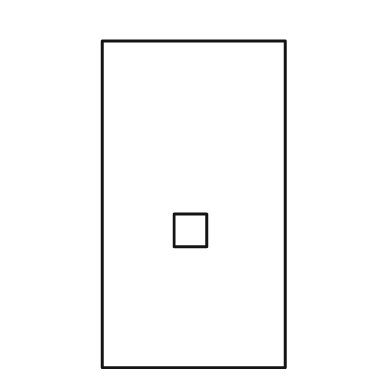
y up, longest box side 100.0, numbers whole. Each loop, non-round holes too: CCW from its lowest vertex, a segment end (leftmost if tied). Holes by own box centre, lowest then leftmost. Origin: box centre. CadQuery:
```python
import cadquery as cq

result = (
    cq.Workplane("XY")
    .moveTo(-28.0, -50.0)
    .lineTo(28.0, -50.0)
    .lineTo(28.0, 50.0)
    .lineTo(-28.0, 50.0)
    .close()
    .moveTo(-6.0, -13.0)
    .lineTo(4.0, -13.0)
    .lineTo(4.0, -3.0)
    .lineTo(-6.0, -3.0)
    .close()
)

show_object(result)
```